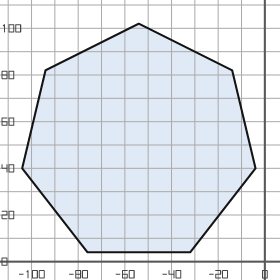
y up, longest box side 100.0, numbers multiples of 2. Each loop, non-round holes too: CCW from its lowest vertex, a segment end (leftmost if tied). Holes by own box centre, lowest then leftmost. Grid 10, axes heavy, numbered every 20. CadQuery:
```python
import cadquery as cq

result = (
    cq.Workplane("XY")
    .moveTo(-76.0, 4.0)
    .lineTo(-32.0, 4.0)
    .lineTo(-4.0, 40.0)
    .lineTo(-14.0, 82.0)
    .lineTo(-54.0, 102.0)
    .lineTo(-94.0, 82.0)
    .lineTo(-104.0, 40.0)
    .close()
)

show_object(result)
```